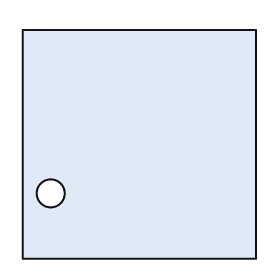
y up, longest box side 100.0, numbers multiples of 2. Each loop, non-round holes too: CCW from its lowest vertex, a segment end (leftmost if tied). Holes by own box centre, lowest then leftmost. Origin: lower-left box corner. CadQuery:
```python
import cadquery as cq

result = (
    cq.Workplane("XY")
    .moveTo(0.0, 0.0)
    .lineTo(100.0, 0.0)
    .lineTo(100.0, 98.0)
    .lineTo(0.0, 98.0)
    .close()
    .moveTo(12.0, 28.0)
    .circle(6.0)
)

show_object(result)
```